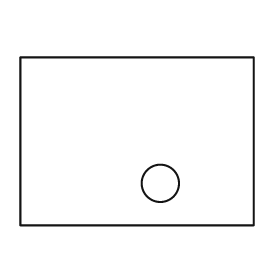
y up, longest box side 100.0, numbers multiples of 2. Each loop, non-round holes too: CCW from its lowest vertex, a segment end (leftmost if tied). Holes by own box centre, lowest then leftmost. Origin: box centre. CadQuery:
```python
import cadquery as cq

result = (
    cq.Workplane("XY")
    .moveTo(-50.0, -36.0)
    .lineTo(50.0, -36.0)
    .lineTo(50.0, 36.0)
    .lineTo(-50.0, 36.0)
    .close()
    .moveTo(10.0, -18.0)
    .circle(8.0)
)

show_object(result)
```